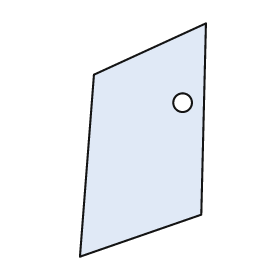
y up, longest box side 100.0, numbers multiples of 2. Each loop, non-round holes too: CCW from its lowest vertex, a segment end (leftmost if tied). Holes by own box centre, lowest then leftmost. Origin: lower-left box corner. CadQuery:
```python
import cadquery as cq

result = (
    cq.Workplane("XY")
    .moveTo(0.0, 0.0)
    .lineTo(52.0, 18.0)
    .lineTo(54.0, 100.0)
    .lineTo(6.0, 78.0)
    .close()
    .moveTo(44.0, 66.0)
    .circle(4.0)
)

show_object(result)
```